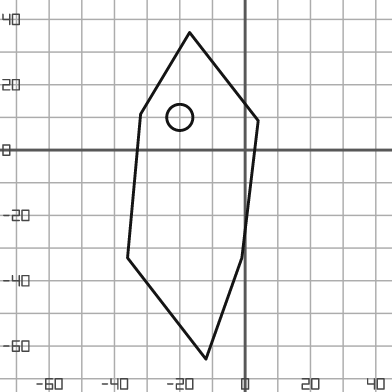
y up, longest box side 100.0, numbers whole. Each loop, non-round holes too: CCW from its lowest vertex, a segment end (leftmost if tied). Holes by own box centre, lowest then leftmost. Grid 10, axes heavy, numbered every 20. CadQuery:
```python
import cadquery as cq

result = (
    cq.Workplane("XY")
    .moveTo(-12.0, -64.0)
    .lineTo(-1.0, -33.0)
    .lineTo(4.0, 9.0)
    .lineTo(-17.0, 36.0)
    .lineTo(-32.0, 11.0)
    .lineTo(-36.0, -33.0)
    .close()
    .moveTo(-20.0, 10.0)
    .circle(4.0)
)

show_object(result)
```